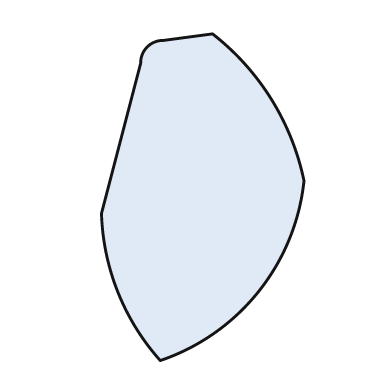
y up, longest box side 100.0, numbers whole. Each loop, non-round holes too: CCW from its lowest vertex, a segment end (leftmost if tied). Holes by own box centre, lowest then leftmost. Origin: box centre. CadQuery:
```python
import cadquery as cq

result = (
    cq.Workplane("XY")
    .moveTo(-13.0, -50.0)
    .threePointArc((17.0, -29.0), (31.0, 5.0))
    .threePointArc((21.0, 30.0), (3.0, 50.0))
    .lineTo(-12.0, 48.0)
    .threePointArc((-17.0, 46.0), (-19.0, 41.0))
    .lineTo(-31.0, -5.0)
    .threePointArc((-26.0, -29.0), (-13.0, -50.0))
    .close()
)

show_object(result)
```